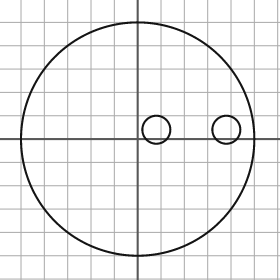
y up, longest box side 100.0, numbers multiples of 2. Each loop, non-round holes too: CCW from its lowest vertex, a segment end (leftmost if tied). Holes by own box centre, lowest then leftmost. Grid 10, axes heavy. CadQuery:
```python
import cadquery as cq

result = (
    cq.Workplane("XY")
    .moveTo(0.0, 0.0)
    .circle(50.0)
    .moveTo(8.0, 4.0)
    .circle(6.0)
    .moveTo(38.0, 4.0)
    .circle(6.0)
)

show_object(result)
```